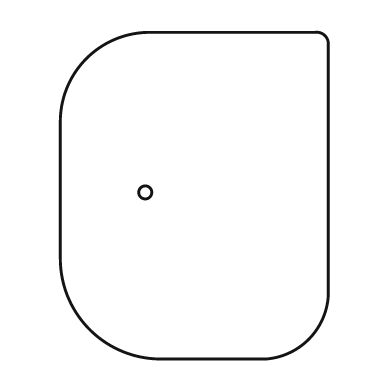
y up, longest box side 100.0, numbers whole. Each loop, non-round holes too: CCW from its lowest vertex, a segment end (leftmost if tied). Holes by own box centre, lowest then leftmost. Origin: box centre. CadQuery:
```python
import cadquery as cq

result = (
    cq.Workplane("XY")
    .moveTo(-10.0, -50.0)
    .lineTo(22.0, -50.0)
    .threePointArc((35.0, -44.0), (41.0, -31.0))
    .lineTo(41.0, 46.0)
    .threePointArc((40.0, 49.0), (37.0, 50.0))
    .lineTo(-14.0, 50.0)
    .threePointArc((-33.0, 42.0), (-41.0, 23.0))
    .lineTo(-41.0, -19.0)
    .threePointArc((-32.0, -41.0), (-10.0, -50.0))
    .close()
    .moveTo(-15.0, 1.0)
    .circle(2.0)
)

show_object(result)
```